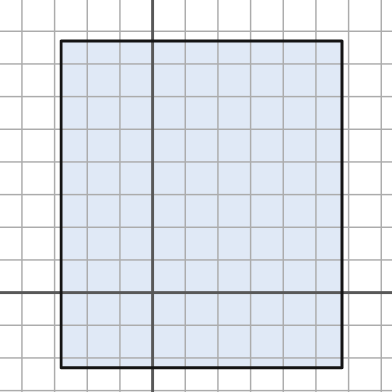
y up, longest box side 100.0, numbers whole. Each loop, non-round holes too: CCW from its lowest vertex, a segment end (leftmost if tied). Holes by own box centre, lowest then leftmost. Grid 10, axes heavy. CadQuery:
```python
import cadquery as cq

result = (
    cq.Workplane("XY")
    .moveTo(-28.0, -23.0)
    .lineTo(58.0, -23.0)
    .lineTo(58.0, 77.0)
    .lineTo(-28.0, 77.0)
    .close()
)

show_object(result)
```